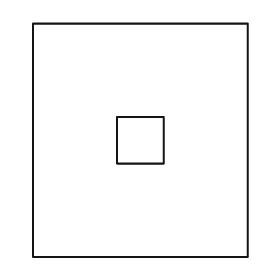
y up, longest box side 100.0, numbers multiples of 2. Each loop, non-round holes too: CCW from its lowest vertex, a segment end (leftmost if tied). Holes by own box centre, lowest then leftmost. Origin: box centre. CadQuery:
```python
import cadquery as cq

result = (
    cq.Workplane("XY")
    .moveTo(-46.0, -50.0)
    .lineTo(46.0, -50.0)
    .lineTo(46.0, 50.0)
    .lineTo(-46.0, 50.0)
    .close()
    .moveTo(-10.0, -10.0)
    .lineTo(10.0, -10.0)
    .lineTo(10.0, 10.0)
    .lineTo(-10.0, 10.0)
    .close()
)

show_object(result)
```